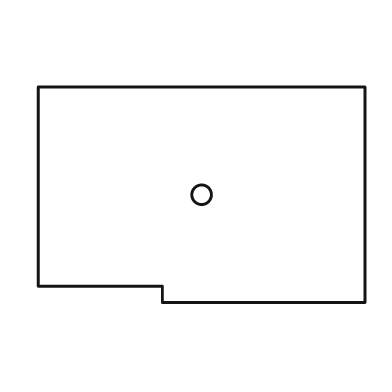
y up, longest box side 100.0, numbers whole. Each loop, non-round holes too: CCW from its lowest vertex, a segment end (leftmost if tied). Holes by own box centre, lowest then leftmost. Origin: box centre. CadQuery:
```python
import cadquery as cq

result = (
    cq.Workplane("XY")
    .moveTo(-12.0, -33.0)
    .lineTo(50.0, -33.0)
    .lineTo(50.0, 33.0)
    .lineTo(-50.0, 33.0)
    .lineTo(-50.0, -28.0)
    .lineTo(-12.0, -28.0)
    .close()
    .moveTo(0.0, 0.0)
    .circle(3.0)
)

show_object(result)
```